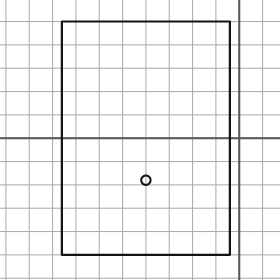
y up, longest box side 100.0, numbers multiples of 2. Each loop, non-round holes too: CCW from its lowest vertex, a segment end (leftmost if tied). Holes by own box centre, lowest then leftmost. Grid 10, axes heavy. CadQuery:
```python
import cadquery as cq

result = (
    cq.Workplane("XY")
    .moveTo(-76.0, -50.0)
    .lineTo(-4.0, -50.0)
    .lineTo(-4.0, 50.0)
    .lineTo(-76.0, 50.0)
    .close()
    .moveTo(-40.0, -18.0)
    .circle(2.0)
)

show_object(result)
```